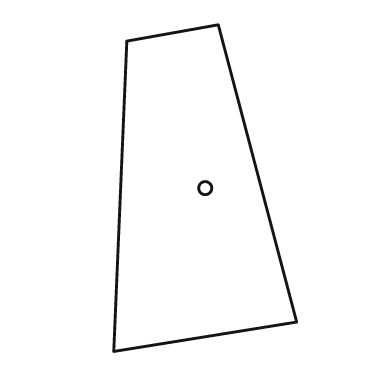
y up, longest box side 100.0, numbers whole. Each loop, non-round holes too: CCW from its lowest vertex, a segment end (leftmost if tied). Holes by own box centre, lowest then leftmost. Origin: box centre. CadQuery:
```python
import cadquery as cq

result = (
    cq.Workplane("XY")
    .moveTo(-28.0, -50.0)
    .lineTo(28.0, -41.0)
    .lineTo(4.0, 50.0)
    .lineTo(-24.0, 45.0)
    .close()
    .moveTo(0.0, 0.0)
    .circle(2.0)
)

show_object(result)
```